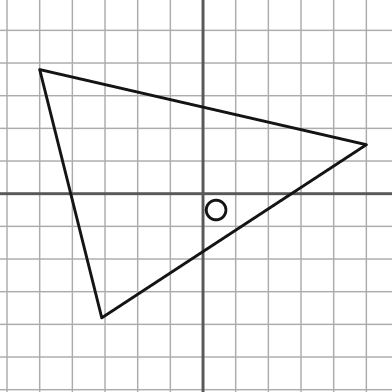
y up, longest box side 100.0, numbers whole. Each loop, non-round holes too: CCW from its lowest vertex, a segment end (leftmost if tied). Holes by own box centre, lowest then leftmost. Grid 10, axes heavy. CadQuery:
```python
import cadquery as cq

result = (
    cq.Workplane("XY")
    .moveTo(-31.0, -38.0)
    .lineTo(50.0, 15.0)
    .lineTo(-50.0, 38.0)
    .close()
    .moveTo(4.0, -5.0)
    .circle(3.0)
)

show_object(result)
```